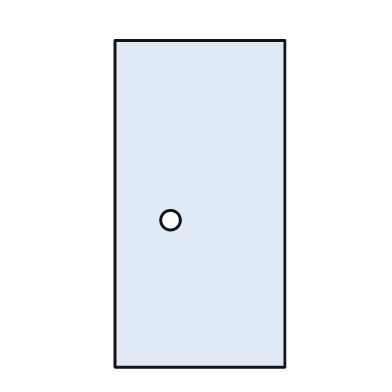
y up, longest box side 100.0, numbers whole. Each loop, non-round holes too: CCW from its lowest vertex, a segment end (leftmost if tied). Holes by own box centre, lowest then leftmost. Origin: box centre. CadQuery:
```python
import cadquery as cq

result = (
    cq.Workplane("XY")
    .moveTo(-26.0, -50.0)
    .lineTo(26.0, -50.0)
    .lineTo(26.0, 50.0)
    .lineTo(-26.0, 50.0)
    .close()
    .moveTo(-9.0, -5.0)
    .circle(3.0)
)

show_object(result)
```